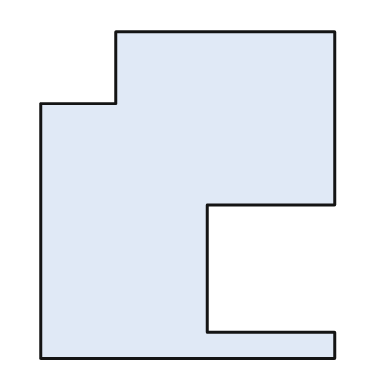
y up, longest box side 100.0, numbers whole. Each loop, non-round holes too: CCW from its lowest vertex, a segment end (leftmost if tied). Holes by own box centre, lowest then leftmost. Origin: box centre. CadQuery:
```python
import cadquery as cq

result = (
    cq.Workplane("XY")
    .moveTo(-45.0, -50.0)
    .lineTo(45.0, -50.0)
    .lineTo(45.0, -42.0)
    .lineTo(6.0, -42.0)
    .lineTo(6.0, -3.0)
    .lineTo(45.0, -3.0)
    .lineTo(45.0, 50.0)
    .lineTo(-22.0, 50.0)
    .lineTo(-22.0, 28.0)
    .lineTo(-45.0, 28.0)
    .close()
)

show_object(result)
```